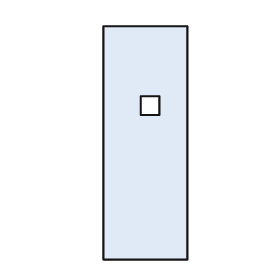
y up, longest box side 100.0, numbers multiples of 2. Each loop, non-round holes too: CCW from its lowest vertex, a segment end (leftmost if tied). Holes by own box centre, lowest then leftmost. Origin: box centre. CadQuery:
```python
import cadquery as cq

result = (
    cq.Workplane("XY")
    .moveTo(-18.0, -50.0)
    .lineTo(18.0, -50.0)
    .lineTo(18.0, 50.0)
    .lineTo(-18.0, 50.0)
    .close()
    .moveTo(-2.0, 12.0)
    .lineTo(6.0, 12.0)
    .lineTo(6.0, 20.0)
    .lineTo(-2.0, 20.0)
    .close()
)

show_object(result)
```